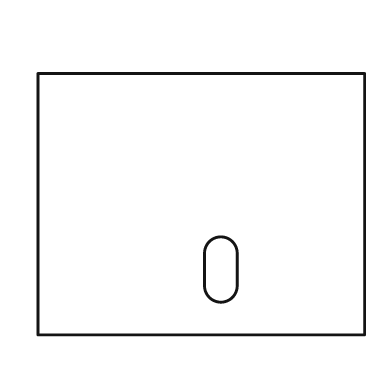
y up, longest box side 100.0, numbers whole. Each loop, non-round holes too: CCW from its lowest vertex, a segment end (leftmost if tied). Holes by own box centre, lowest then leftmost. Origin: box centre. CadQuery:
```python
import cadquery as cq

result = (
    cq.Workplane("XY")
    .moveTo(-50.0, -40.0)
    .lineTo(50.0, -40.0)
    .lineTo(50.0, 40.0)
    .lineTo(-50.0, 40.0)
    .close()
    .moveTo(1.0, -25.0)
    .threePointArc((6.0, -30.0), (11.0, -25.0))
    .lineTo(11.0, -15.0)
    .threePointArc((6.0, -10.0), (1.0, -15.0))
    .close()
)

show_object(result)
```